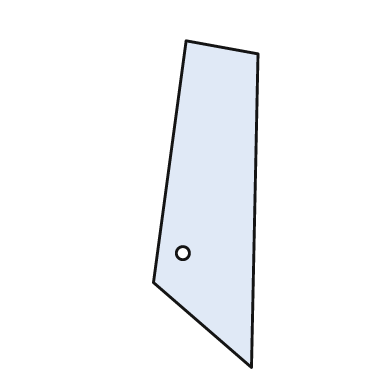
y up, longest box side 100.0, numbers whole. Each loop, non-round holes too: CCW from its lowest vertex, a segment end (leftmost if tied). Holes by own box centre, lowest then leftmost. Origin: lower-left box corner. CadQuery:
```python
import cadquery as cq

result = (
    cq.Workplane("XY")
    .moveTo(30.0, 0.0)
    .lineTo(32.0, 96.0)
    .lineTo(10.0, 100.0)
    .lineTo(0.0, 26.0)
    .close()
    .moveTo(9.0, 35.0)
    .circle(2.0)
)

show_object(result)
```